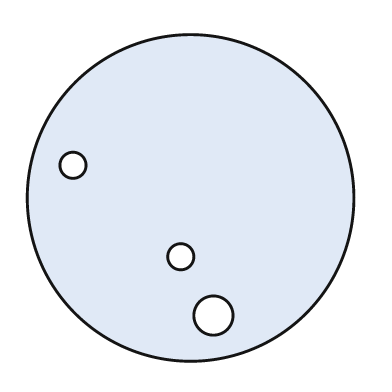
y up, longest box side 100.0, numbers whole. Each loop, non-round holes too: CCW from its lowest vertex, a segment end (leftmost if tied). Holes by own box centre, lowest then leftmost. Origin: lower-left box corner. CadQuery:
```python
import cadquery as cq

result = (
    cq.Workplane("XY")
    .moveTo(50.0, 50.0)
    .circle(50.0)
    .moveTo(57.0, 14.0)
    .circle(6.0)
    .moveTo(47.0, 32.0)
    .circle(4.0)
    .moveTo(14.0, 60.0)
    .circle(4.0)
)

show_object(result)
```